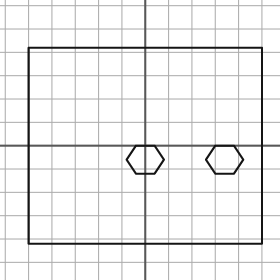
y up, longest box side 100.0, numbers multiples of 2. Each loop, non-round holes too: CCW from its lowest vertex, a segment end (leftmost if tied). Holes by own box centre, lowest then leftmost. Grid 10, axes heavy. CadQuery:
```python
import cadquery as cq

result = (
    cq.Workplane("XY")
    .moveTo(-50.0, -42.0)
    .lineTo(50.0, -42.0)
    .lineTo(50.0, 42.0)
    .lineTo(-50.0, 42.0)
    .close()
    .moveTo(-4.0, -12.0)
    .lineTo(4.0, -12.0)
    .lineTo(8.0, -6.0)
    .lineTo(4.0, 0.0)
    .lineTo(-4.0, 0.0)
    .lineTo(-8.0, -6.0)
    .close()
    .moveTo(30.0, -12.0)
    .lineTo(38.0, -12.0)
    .lineTo(42.0, -6.0)
    .lineTo(38.0, 0.0)
    .lineTo(30.0, 0.0)
    .lineTo(26.0, -6.0)
    .close()
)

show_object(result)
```